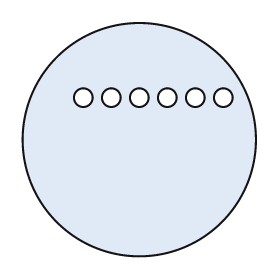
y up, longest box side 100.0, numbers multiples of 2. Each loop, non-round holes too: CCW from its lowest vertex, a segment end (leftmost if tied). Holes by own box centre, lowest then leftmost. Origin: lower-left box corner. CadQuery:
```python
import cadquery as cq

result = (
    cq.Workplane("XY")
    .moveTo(50.0, 50.0)
    .circle(50.0)
    .moveTo(26.0, 68.0)
    .circle(4.0)
    .moveTo(38.0, 68.0)
    .circle(4.0)
    .moveTo(50.0, 68.0)
    .circle(4.0)
    .moveTo(62.0, 68.0)
    .circle(4.0)
    .moveTo(74.0, 68.0)
    .circle(4.0)
    .moveTo(86.0, 68.0)
    .circle(4.0)
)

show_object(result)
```